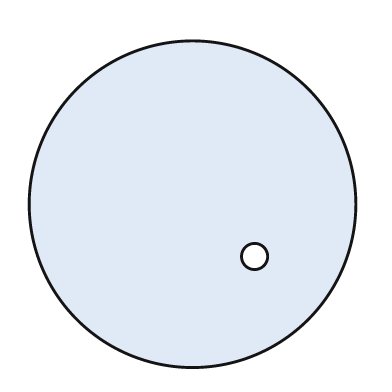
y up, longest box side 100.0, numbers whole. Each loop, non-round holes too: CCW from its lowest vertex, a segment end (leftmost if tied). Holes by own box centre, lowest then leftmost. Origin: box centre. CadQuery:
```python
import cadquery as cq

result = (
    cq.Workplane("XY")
    .moveTo(0.0, 0.0)
    .circle(50.0)
    .moveTo(19.0, -16.0)
    .circle(4.0)
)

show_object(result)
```